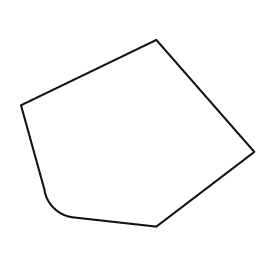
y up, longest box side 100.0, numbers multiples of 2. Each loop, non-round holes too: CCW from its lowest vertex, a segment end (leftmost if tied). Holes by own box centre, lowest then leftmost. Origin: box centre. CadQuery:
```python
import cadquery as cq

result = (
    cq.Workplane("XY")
    .moveTo(8.0, -40.0)
    .lineTo(50.0, -8.0)
    .lineTo(8.0, 40.0)
    .lineTo(-50.0, 12.0)
    .lineTo(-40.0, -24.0)
    .threePointArc((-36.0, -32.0), (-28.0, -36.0))
    .close()
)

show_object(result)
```